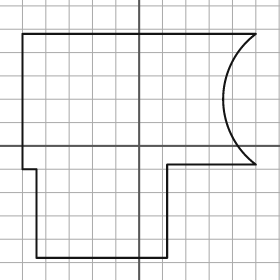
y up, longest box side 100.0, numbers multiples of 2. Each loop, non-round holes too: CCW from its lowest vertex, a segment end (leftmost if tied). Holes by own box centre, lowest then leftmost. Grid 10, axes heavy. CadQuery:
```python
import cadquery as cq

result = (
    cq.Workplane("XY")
    .moveTo(-44.0, -48.0)
    .lineTo(12.0, -48.0)
    .lineTo(12.0, -8.0)
    .lineTo(50.0, -8.0)
    .threePointArc((36.0, 20.0), (50.0, 48.0))
    .lineTo(-50.0, 48.0)
    .lineTo(-50.0, -10.0)
    .lineTo(-44.0, -10.0)
    .close()
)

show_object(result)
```